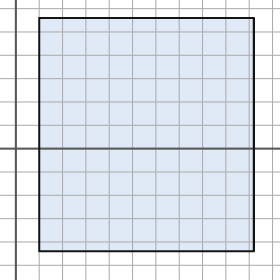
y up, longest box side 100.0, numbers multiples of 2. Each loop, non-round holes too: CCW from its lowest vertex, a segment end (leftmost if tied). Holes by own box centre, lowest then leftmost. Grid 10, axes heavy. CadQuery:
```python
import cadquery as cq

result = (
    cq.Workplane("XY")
    .moveTo(10.0, -44.0)
    .lineTo(102.0, -44.0)
    .lineTo(102.0, 56.0)
    .lineTo(10.0, 56.0)
    .close()
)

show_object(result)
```